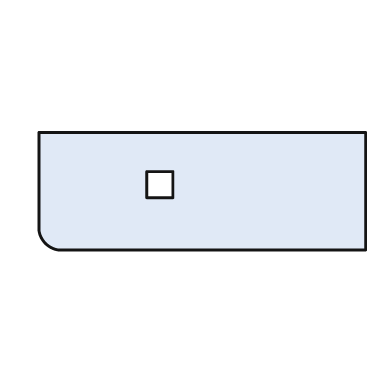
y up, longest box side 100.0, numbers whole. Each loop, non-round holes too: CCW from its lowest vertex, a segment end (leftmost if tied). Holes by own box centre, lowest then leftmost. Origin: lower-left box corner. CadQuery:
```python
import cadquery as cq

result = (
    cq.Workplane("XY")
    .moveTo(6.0, 0.0)
    .lineTo(100.0, 0.0)
    .lineTo(100.0, 36.0)
    .lineTo(0.0, 36.0)
    .lineTo(0.0, 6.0)
    .threePointArc((2.0, 2.0), (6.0, 0.0))
    .close()
    .moveTo(33.0, 16.0)
    .lineTo(41.0, 16.0)
    .lineTo(41.0, 24.0)
    .lineTo(33.0, 24.0)
    .close()
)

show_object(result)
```